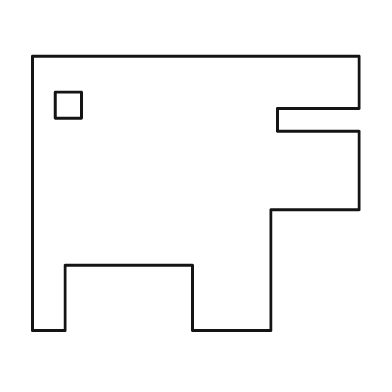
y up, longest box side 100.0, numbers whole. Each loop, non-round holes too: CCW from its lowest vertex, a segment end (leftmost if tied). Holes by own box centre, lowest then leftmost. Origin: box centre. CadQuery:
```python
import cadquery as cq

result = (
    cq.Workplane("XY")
    .moveTo(-50.0, -42.0)
    .lineTo(-40.0, -42.0)
    .lineTo(-40.0, -22.0)
    .lineTo(-1.0, -22.0)
    .lineTo(-1.0, -42.0)
    .lineTo(23.0, -42.0)
    .lineTo(23.0, -5.0)
    .lineTo(50.0, -5.0)
    .lineTo(50.0, 19.0)
    .lineTo(25.0, 19.0)
    .lineTo(25.0, 26.0)
    .lineTo(50.0, 26.0)
    .lineTo(50.0, 42.0)
    .lineTo(-50.0, 42.0)
    .close()
    .moveTo(-43.0, 23.0)
    .lineTo(-35.0, 23.0)
    .lineTo(-35.0, 31.0)
    .lineTo(-43.0, 31.0)
    .close()
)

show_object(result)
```